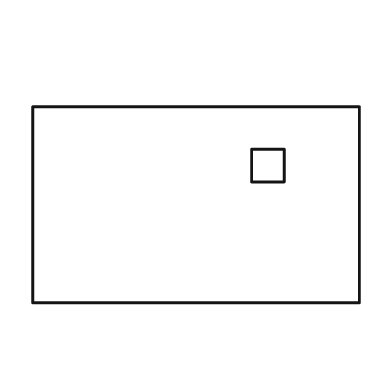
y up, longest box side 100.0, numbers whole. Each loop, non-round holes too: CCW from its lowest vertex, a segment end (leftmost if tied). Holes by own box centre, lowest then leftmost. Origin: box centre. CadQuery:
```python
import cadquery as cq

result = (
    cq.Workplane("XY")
    .moveTo(-50.0, -30.0)
    .lineTo(50.0, -30.0)
    .lineTo(50.0, 30.0)
    .lineTo(-50.0, 30.0)
    .close()
    .moveTo(17.0, 7.0)
    .lineTo(27.0, 7.0)
    .lineTo(27.0, 17.0)
    .lineTo(17.0, 17.0)
    .close()
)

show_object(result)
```